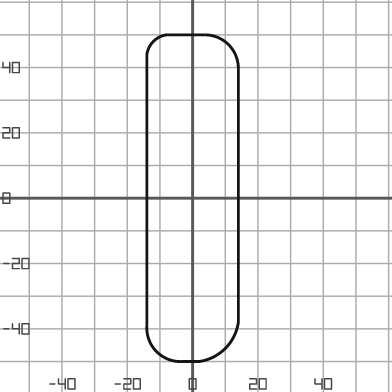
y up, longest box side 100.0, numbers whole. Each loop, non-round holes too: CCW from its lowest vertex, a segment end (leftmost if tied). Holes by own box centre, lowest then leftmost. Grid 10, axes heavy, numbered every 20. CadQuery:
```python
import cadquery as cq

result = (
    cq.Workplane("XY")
    .moveTo(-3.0, -50.0)
    .lineTo(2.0, -50.0)
    .threePointArc((10.0, -46.0), (14.0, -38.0))
    .lineTo(14.0, 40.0)
    .threePointArc((11.0, 47.0), (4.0, 50.0))
    .lineTo(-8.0, 50.0)
    .threePointArc((-12.0, 48.0), (-14.0, 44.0))
    .lineTo(-14.0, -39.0)
    .threePointArc((-11.0, -47.0), (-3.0, -50.0))
    .close()
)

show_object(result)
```